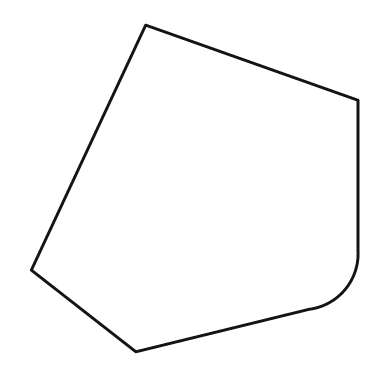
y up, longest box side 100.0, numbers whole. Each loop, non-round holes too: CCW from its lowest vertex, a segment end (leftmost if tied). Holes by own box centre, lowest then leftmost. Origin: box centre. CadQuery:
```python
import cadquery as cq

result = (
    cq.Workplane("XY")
    .moveTo(-18.0, -50.0)
    .lineTo(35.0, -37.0)
    .threePointArc((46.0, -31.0), (50.0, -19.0))
    .lineTo(50.0, 27.0)
    .lineTo(-15.0, 50.0)
    .lineTo(-50.0, -25.0)
    .close()
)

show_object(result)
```